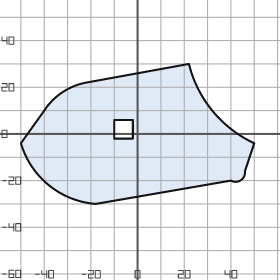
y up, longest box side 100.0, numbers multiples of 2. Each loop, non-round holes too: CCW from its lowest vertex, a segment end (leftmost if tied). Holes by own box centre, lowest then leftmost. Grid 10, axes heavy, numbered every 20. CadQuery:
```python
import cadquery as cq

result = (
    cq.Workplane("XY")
    .moveTo(-18.0, -30.0)
    .lineTo(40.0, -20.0)
    .threePointArc((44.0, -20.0), (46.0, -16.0))
    .lineTo(50.0, -4.0)
    .threePointArc((32.0, 10.0), (22.0, 30.0))
    .lineTo(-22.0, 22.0)
    .threePointArc((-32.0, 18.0), (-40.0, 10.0))
    .lineTo(-50.0, -4.0)
    .threePointArc((-38.0, -22.0), (-18.0, -30.0))
    .close()
    .moveTo(-10.0, -2.0)
    .lineTo(-2.0, -2.0)
    .lineTo(-2.0, 6.0)
    .lineTo(-10.0, 6.0)
    .close()
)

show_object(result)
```